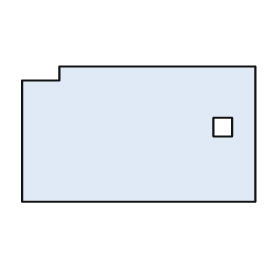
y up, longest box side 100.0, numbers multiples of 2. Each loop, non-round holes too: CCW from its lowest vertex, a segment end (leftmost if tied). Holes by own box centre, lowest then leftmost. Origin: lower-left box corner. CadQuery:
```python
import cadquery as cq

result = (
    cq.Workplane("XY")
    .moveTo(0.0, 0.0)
    .lineTo(100.0, 0.0)
    .lineTo(100.0, 58.0)
    .lineTo(16.0, 58.0)
    .lineTo(16.0, 52.0)
    .lineTo(0.0, 52.0)
    .close()
    .moveTo(82.0, 28.0)
    .lineTo(90.0, 28.0)
    .lineTo(90.0, 36.0)
    .lineTo(82.0, 36.0)
    .close()
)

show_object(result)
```